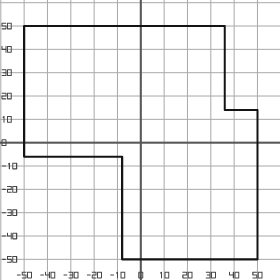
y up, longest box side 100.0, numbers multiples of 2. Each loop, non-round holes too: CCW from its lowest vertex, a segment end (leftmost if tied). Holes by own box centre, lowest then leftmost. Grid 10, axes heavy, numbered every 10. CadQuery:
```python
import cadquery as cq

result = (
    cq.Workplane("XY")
    .moveTo(-8.0, -50.0)
    .lineTo(50.0, -50.0)
    .lineTo(50.0, 14.0)
    .lineTo(36.0, 14.0)
    .lineTo(36.0, 50.0)
    .lineTo(-50.0, 50.0)
    .lineTo(-50.0, -6.0)
    .lineTo(-8.0, -6.0)
    .close()
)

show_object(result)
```